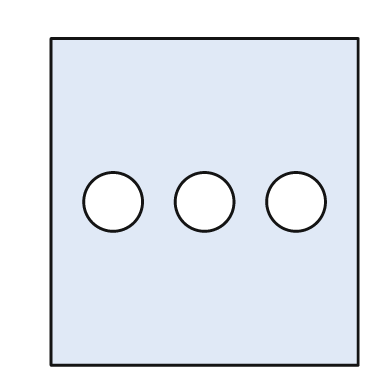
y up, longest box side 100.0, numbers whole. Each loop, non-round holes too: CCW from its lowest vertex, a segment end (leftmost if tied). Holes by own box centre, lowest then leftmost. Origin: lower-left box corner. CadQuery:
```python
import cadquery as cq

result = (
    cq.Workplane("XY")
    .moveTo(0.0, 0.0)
    .lineTo(94.0, 0.0)
    .lineTo(94.0, 100.0)
    .lineTo(0.0, 100.0)
    .close()
    .moveTo(19.0, 50.0)
    .circle(9.0)
    .moveTo(47.0, 50.0)
    .circle(9.0)
    .moveTo(75.0, 50.0)
    .circle(9.0)
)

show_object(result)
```